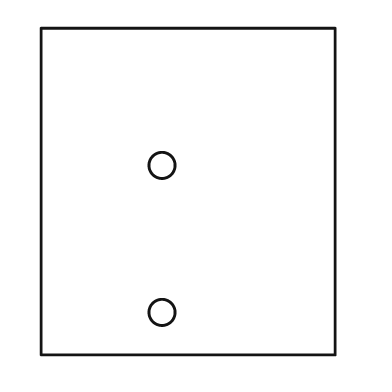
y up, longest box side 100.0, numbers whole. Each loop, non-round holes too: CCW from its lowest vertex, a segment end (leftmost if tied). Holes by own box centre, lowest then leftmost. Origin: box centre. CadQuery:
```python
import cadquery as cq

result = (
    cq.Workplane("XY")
    .moveTo(-45.0, -50.0)
    .lineTo(45.0, -50.0)
    .lineTo(45.0, 50.0)
    .lineTo(-45.0, 50.0)
    .close()
    .moveTo(-8.0, -37.0)
    .circle(4.0)
    .moveTo(-8.0, 8.0)
    .circle(4.0)
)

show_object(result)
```